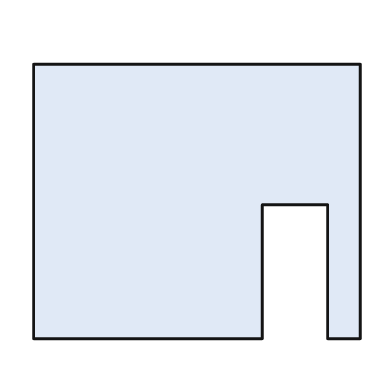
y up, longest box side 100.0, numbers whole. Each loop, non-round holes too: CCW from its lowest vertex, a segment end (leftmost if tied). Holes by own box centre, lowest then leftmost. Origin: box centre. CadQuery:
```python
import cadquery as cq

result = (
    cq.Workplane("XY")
    .moveTo(-50.0, -42.0)
    .lineTo(20.0, -42.0)
    .lineTo(20.0, -1.0)
    .lineTo(40.0, -1.0)
    .lineTo(40.0, -42.0)
    .lineTo(50.0, -42.0)
    .lineTo(50.0, 42.0)
    .lineTo(-50.0, 42.0)
    .close()
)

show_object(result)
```